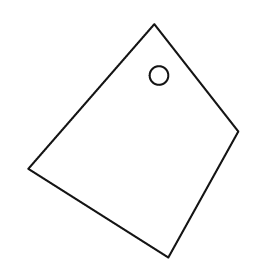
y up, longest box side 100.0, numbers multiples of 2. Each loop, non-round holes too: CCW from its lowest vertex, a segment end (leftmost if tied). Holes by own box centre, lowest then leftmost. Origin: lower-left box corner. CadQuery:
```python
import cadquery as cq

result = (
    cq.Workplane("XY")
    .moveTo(60.0, 0.0)
    .lineTo(90.0, 54.0)
    .lineTo(54.0, 100.0)
    .lineTo(0.0, 38.0)
    .close()
    .moveTo(56.0, 78.0)
    .circle(4.0)
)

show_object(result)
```